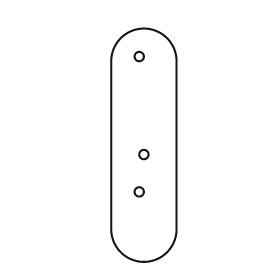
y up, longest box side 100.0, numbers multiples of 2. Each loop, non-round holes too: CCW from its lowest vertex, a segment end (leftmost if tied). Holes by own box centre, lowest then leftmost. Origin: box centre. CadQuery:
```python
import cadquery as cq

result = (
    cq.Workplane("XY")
    .moveTo(-14.0, -36.0)
    .threePointArc((0.0, -50.0), (14.0, -36.0))
    .lineTo(14.0, 36.0)
    .threePointArc((0.0, 50.0), (-14.0, 36.0))
    .close()
    .moveTo(-2.0, -20.0)
    .circle(2.0)
    .moveTo(0.0, -4.0)
    .circle(2.0)
    .moveTo(-2.0, 38.0)
    .circle(2.0)
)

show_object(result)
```